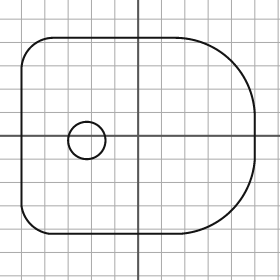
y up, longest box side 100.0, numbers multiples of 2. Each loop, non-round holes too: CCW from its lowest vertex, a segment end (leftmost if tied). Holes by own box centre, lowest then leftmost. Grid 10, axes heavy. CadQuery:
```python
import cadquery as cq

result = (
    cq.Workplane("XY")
    .moveTo(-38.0, -42.0)
    .lineTo(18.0, -42.0)
    .threePointArc((40.0, -32.0), (50.0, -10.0))
    .lineTo(50.0, 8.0)
    .threePointArc((40.0, 32.0), (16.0, 42.0))
    .lineTo(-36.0, 42.0)
    .threePointArc((-46.0, 38.0), (-50.0, 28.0))
    .lineTo(-50.0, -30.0)
    .threePointArc((-46.0, -38.0), (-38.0, -42.0))
    .close()
    .moveTo(-22.0, -2.0)
    .circle(8.0)
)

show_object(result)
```